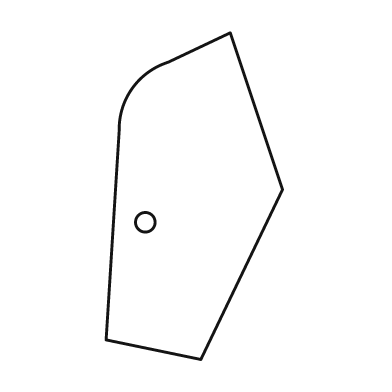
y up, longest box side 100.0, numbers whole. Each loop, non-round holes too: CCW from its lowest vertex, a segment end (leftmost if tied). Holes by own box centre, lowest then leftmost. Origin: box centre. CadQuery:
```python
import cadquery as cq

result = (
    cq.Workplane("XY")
    .moveTo(2.0, -50.0)
    .lineTo(27.0, 2.0)
    .lineTo(11.0, 50.0)
    .lineTo(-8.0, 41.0)
    .threePointArc((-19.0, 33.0), (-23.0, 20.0))
    .lineTo(-27.0, -44.0)
    .close()
    .moveTo(-15.0, -8.0)
    .circle(3.0)
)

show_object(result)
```